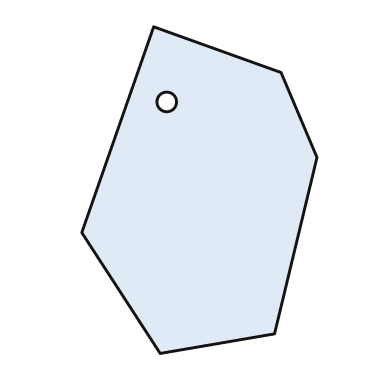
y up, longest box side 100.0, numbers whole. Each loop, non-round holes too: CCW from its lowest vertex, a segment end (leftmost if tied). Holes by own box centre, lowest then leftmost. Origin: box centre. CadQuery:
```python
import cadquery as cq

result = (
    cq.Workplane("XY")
    .moveTo(-12.0, -50.0)
    .lineTo(23.0, -44.0)
    .lineTo(36.0, 10.0)
    .lineTo(25.0, 36.0)
    .lineTo(-14.0, 50.0)
    .lineTo(-36.0, -13.0)
    .close()
    .moveTo(-10.0, 27.0)
    .circle(3.0)
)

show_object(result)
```